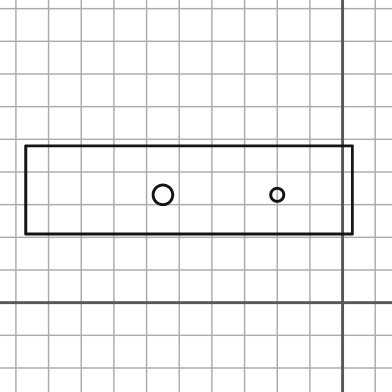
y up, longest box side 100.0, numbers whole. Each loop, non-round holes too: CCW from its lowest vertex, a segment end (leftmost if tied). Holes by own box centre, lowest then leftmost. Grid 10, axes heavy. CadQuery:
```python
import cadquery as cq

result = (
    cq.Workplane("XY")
    .moveTo(-97.0, 21.0)
    .lineTo(3.0, 21.0)
    .lineTo(3.0, 48.0)
    .lineTo(-97.0, 48.0)
    .close()
    .moveTo(-55.0, 33.0)
    .circle(3.0)
    .moveTo(-20.0, 33.0)
    .circle(2.0)
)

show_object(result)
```